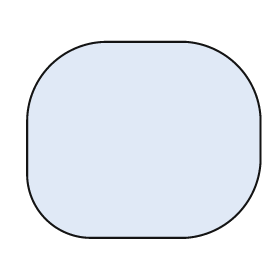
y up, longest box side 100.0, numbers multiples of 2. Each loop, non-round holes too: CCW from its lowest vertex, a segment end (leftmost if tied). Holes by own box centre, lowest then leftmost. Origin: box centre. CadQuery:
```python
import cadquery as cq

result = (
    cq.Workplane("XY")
    .moveTo(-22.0, -42.0)
    .lineTo(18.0, -42.0)
    .threePointArc((40.0, -32.0), (50.0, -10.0))
    .lineTo(50.0, 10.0)
    .threePointArc((40.0, 32.0), (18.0, 42.0))
    .lineTo(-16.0, 42.0)
    .threePointArc((-40.0, 32.0), (-50.0, 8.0))
    .lineTo(-50.0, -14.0)
    .threePointArc((-42.0, -34.0), (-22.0, -42.0))
    .close()
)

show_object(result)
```